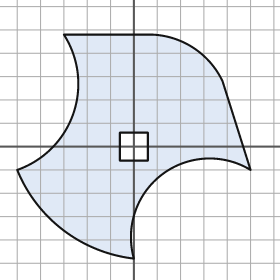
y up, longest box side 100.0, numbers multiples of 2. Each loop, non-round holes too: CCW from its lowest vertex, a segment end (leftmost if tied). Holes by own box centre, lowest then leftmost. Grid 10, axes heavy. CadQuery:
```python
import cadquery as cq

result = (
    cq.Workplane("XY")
    .moveTo(0.0, -48.0)
    .threePointArc((12.0, -12.0), (50.0, -10.0))
    .lineTo(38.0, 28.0)
    .threePointArc((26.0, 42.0), (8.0, 48.0))
    .lineTo(-30.0, 48.0)
    .threePointArc((-26.0, 14.0), (-50.0, -10.0))
    .threePointArc((-30.0, -36.0), (0.0, -48.0))
    .close()
    .moveTo(-6.0, -6.0)
    .lineTo(6.0, -6.0)
    .lineTo(6.0, 6.0)
    .lineTo(-6.0, 6.0)
    .close()
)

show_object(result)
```